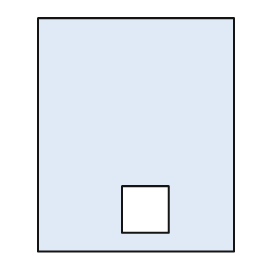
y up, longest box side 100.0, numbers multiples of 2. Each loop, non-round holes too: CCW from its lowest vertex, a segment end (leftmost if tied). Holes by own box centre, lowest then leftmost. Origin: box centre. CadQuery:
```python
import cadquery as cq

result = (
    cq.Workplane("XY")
    .moveTo(-42.0, -50.0)
    .lineTo(42.0, -50.0)
    .lineTo(42.0, 50.0)
    .lineTo(-42.0, 50.0)
    .close()
    .moveTo(-6.0, -42.0)
    .lineTo(14.0, -42.0)
    .lineTo(14.0, -22.0)
    .lineTo(-6.0, -22.0)
    .close()
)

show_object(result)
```